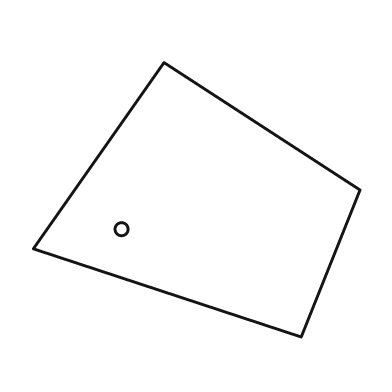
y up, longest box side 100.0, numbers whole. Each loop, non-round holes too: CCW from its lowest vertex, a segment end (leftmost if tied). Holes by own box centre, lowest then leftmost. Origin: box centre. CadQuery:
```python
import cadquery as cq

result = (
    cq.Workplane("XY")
    .moveTo(32.0, -42.0)
    .lineTo(50.0, 3.0)
    .lineTo(-10.0, 42.0)
    .lineTo(-50.0, -15.0)
    .close()
    .moveTo(-23.0, -9.0)
    .circle(2.0)
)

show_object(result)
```